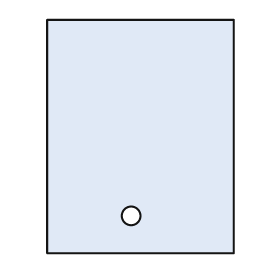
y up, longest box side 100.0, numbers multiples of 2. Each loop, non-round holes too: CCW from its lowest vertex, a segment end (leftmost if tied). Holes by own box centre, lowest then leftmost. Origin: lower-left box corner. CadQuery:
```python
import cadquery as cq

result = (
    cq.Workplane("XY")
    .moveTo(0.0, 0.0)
    .lineTo(80.0, 0.0)
    .lineTo(80.0, 100.0)
    .lineTo(0.0, 100.0)
    .close()
    .moveTo(36.0, 16.0)
    .circle(4.0)
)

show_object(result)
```